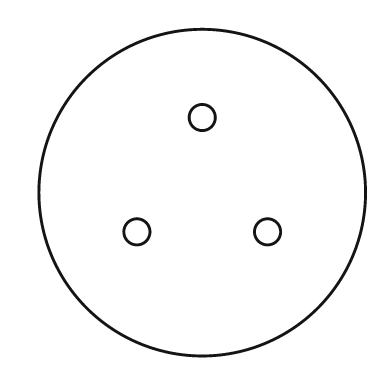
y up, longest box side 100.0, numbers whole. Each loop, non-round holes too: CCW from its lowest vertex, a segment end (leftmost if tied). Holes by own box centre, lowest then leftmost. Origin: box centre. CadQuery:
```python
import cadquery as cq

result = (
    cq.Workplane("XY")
    .moveTo(0.0, 0.0)
    .circle(50.0)
    .moveTo(-20.0, -12.0)
    .circle(4.0)
    .moveTo(20.0, -12.0)
    .circle(4.0)
    .moveTo(0.0, 23.0)
    .circle(4.0)
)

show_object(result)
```